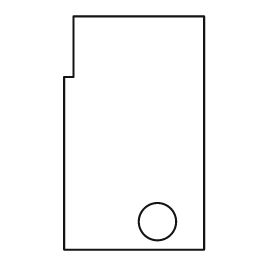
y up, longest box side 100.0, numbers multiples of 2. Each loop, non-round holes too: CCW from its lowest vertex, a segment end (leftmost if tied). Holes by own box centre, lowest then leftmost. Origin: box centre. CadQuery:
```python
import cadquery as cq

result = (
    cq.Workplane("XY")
    .moveTo(-30.0, -50.0)
    .lineTo(30.0, -50.0)
    .lineTo(30.0, 50.0)
    .lineTo(-26.0, 50.0)
    .lineTo(-26.0, 24.0)
    .lineTo(-30.0, 24.0)
    .close()
    .moveTo(10.0, -38.0)
    .circle(8.0)
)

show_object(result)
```